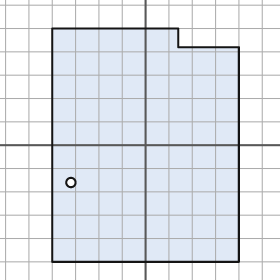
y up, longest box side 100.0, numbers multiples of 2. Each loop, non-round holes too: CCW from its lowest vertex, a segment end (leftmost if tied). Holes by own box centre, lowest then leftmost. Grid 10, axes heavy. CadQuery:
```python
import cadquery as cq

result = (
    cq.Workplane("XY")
    .moveTo(-40.0, -50.0)
    .lineTo(40.0, -50.0)
    .lineTo(40.0, 42.0)
    .lineTo(14.0, 42.0)
    .lineTo(14.0, 50.0)
    .lineTo(-40.0, 50.0)
    .close()
    .moveTo(-32.0, -16.0)
    .circle(2.0)
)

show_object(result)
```